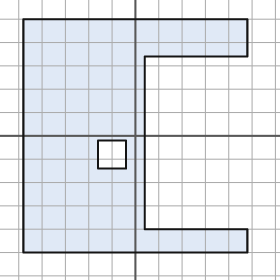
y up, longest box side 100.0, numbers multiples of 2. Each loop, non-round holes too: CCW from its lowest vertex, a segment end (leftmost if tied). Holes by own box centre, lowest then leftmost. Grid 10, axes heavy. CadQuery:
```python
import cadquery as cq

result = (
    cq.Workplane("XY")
    .moveTo(-48.0, -50.0)
    .lineTo(48.0, -50.0)
    .lineTo(48.0, -40.0)
    .lineTo(4.0, -40.0)
    .lineTo(4.0, 34.0)
    .lineTo(48.0, 34.0)
    .lineTo(48.0, 50.0)
    .lineTo(-48.0, 50.0)
    .close()
    .moveTo(-16.0, -14.0)
    .lineTo(-4.0, -14.0)
    .lineTo(-4.0, -2.0)
    .lineTo(-16.0, -2.0)
    .close()
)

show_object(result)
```